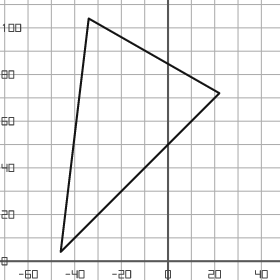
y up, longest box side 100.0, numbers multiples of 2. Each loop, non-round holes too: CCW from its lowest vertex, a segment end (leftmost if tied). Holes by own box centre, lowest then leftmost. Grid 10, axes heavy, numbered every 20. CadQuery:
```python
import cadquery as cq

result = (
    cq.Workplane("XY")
    .moveTo(-46.0, 4.0)
    .lineTo(22.0, 72.0)
    .lineTo(-34.0, 104.0)
    .close()
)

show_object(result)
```